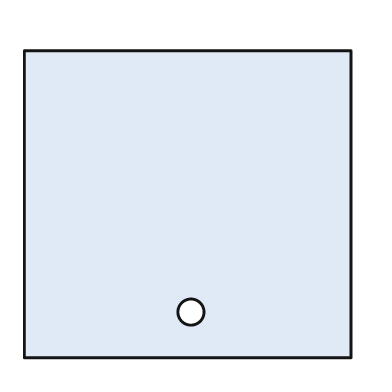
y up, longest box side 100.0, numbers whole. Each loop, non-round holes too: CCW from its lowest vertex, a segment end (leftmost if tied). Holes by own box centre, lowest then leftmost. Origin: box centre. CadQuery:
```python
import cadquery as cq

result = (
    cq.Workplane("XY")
    .moveTo(-50.0, -47.0)
    .lineTo(50.0, -47.0)
    .lineTo(50.0, 47.0)
    .lineTo(-50.0, 47.0)
    .close()
    .moveTo(1.0, -33.0)
    .circle(4.0)
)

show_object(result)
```